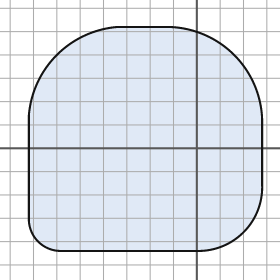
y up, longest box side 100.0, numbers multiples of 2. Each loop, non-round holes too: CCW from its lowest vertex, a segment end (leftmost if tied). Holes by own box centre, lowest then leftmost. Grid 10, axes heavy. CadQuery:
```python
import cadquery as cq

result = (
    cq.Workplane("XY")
    .moveTo(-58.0, -44.0)
    .lineTo(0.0, -44.0)
    .threePointArc((20.0, -36.0), (28.0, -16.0))
    .lineTo(28.0, 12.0)
    .threePointArc((16.0, 40.0), (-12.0, 52.0))
    .lineTo(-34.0, 52.0)
    .threePointArc((-60.0, 40.0), (-72.0, 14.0))
    .lineTo(-72.0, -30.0)
    .threePointArc((-68.0, -40.0), (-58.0, -44.0))
    .close()
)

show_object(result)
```